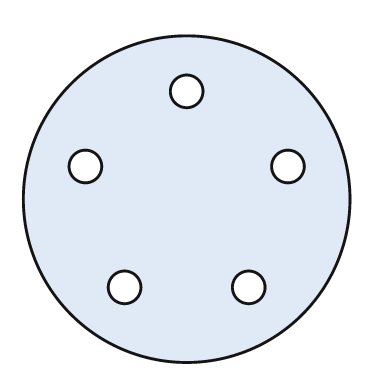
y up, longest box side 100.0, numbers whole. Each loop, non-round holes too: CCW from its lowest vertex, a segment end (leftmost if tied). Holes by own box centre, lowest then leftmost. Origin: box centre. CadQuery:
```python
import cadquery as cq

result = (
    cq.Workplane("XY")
    .moveTo(0.0, 0.0)
    .circle(50.0)
    .moveTo(-19.0, -27.0)
    .circle(5.0)
    .moveTo(19.0, -27.0)
    .circle(5.0)
    .moveTo(-31.0, 10.0)
    .circle(5.0)
    .moveTo(31.0, 10.0)
    .circle(5.0)
    .moveTo(0.0, 33.0)
    .circle(5.0)
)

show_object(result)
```